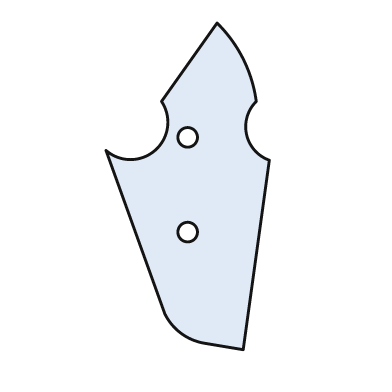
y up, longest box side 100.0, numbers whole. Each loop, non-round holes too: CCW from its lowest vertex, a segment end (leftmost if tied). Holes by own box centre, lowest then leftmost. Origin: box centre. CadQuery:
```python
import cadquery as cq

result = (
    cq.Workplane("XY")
    .moveTo(17.0, -50.0)
    .lineTo(25.0, 8.0)
    .threePointArc((18.0, 16.0), (21.0, 26.0))
    .threePointArc((17.0, 39.0), (9.0, 50.0))
    .lineTo(-8.0, 26.0)
    .threePointArc((-10.0, 11.0), (-25.0, 11.0))
    .lineTo(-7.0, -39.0)
    .threePointArc((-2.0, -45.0), (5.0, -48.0))
    .close()
    .moveTo(0.0, -14.0)
    .circle(3.0)
    .moveTo(0.0, 15.0)
    .circle(3.0)
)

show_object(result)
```